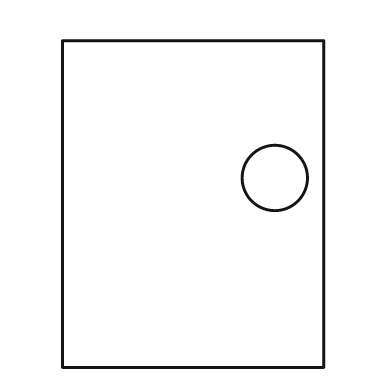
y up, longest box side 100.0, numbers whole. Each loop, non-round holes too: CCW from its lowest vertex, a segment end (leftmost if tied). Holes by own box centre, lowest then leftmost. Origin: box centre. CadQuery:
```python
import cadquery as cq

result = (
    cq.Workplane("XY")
    .moveTo(-40.0, -50.0)
    .lineTo(40.0, -50.0)
    .lineTo(40.0, 50.0)
    .lineTo(-40.0, 50.0)
    .close()
    .moveTo(25.0, 8.0)
    .circle(10.0)
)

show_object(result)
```